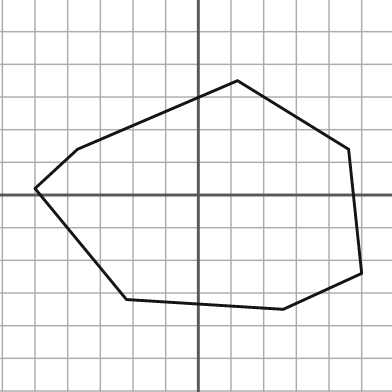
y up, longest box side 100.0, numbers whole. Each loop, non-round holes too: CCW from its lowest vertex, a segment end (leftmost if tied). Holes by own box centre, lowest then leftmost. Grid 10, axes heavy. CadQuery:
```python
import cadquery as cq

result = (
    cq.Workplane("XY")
    .moveTo(26.0, -35.0)
    .lineTo(50.0, -24.0)
    .lineTo(46.0, 14.0)
    .lineTo(12.0, 35.0)
    .lineTo(-37.0, 14.0)
    .lineTo(-50.0, 2.0)
    .lineTo(-22.0, -32.0)
    .close()
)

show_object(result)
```